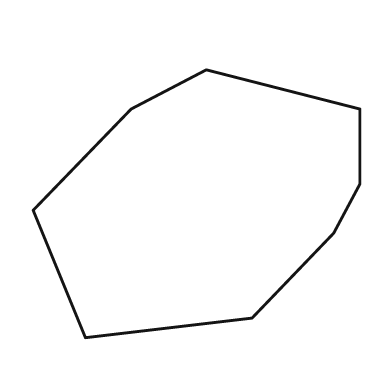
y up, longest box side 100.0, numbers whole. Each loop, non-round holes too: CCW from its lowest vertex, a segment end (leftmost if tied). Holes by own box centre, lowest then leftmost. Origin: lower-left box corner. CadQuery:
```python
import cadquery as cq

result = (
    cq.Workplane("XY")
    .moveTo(16.0, 0.0)
    .lineTo(67.0, 6.0)
    .lineTo(92.0, 32.0)
    .lineTo(100.0, 47.0)
    .lineTo(100.0, 70.0)
    .lineTo(53.0, 82.0)
    .lineTo(30.0, 70.0)
    .lineTo(0.0, 39.0)
    .close()
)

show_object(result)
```